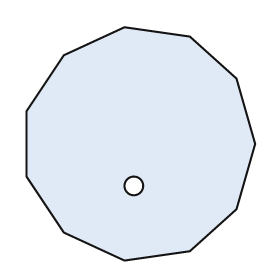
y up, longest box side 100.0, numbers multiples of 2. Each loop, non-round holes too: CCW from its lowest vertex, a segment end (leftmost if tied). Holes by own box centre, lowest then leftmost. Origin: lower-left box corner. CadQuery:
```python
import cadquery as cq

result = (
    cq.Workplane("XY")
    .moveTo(42.0, 0.0)
    .lineTo(70.0, 4.0)
    .lineTo(90.0, 22.0)
    .lineTo(98.0, 50.0)
    .lineTo(90.0, 78.0)
    .lineTo(70.0, 96.0)
    .lineTo(42.0, 100.0)
    .lineTo(16.0, 88.0)
    .lineTo(0.0, 64.0)
    .lineTo(0.0, 36.0)
    .lineTo(16.0, 12.0)
    .close()
    .moveTo(46.0, 32.0)
    .circle(4.0)
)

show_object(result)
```